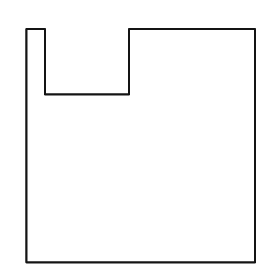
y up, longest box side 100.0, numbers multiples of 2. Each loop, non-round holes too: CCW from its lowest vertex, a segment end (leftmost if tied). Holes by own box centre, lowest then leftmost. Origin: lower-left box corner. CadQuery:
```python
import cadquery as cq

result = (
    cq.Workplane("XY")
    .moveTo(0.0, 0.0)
    .lineTo(98.0, 0.0)
    .lineTo(98.0, 100.0)
    .lineTo(44.0, 100.0)
    .lineTo(44.0, 72.0)
    .lineTo(8.0, 72.0)
    .lineTo(8.0, 100.0)
    .lineTo(0.0, 100.0)
    .close()
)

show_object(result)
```